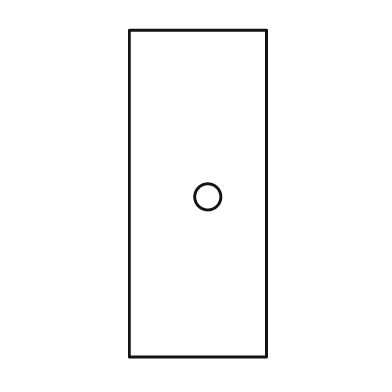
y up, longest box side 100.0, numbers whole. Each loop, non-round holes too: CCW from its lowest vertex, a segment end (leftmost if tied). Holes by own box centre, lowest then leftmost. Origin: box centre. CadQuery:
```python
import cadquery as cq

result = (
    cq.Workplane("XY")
    .moveTo(-21.0, -50.0)
    .lineTo(21.0, -50.0)
    .lineTo(21.0, 50.0)
    .lineTo(-21.0, 50.0)
    .close()
    .moveTo(3.0, -1.0)
    .circle(4.0)
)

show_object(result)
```